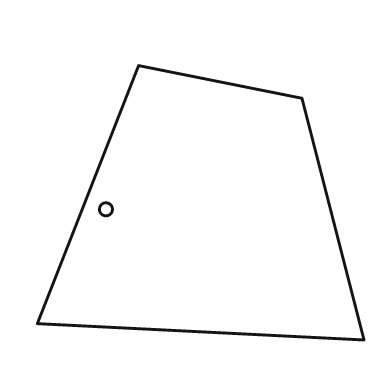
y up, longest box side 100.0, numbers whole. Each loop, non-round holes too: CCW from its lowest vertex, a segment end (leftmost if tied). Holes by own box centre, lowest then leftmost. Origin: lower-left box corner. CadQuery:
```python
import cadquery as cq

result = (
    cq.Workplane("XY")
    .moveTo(100.0, 0.0)
    .lineTo(81.0, 74.0)
    .lineTo(31.0, 84.0)
    .lineTo(0.0, 5.0)
    .close()
    .moveTo(21.0, 40.0)
    .circle(2.0)
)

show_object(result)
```